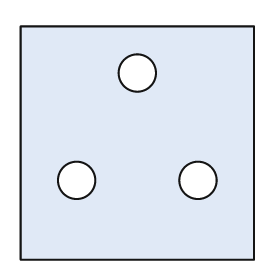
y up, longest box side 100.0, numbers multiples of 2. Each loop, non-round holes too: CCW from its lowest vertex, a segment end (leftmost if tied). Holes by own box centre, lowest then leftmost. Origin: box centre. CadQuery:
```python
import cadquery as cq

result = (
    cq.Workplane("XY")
    .moveTo(-50.0, -50.0)
    .lineTo(50.0, -50.0)
    .lineTo(50.0, 50.0)
    .lineTo(-50.0, 50.0)
    .close()
    .moveTo(-26.0, -16.0)
    .circle(8.0)
    .moveTo(26.0, -16.0)
    .circle(8.0)
    .moveTo(0.0, 30.0)
    .circle(8.0)
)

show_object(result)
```